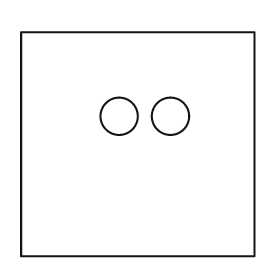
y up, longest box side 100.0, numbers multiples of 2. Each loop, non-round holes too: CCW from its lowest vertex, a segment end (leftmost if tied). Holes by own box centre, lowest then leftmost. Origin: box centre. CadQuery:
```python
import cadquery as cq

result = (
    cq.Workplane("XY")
    .moveTo(-50.0, -48.0)
    .lineTo(50.0, -48.0)
    .lineTo(50.0, 48.0)
    .lineTo(-50.0, 48.0)
    .close()
    .moveTo(-8.0, 12.0)
    .circle(8.0)
    .moveTo(14.0, 12.0)
    .circle(8.0)
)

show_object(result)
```